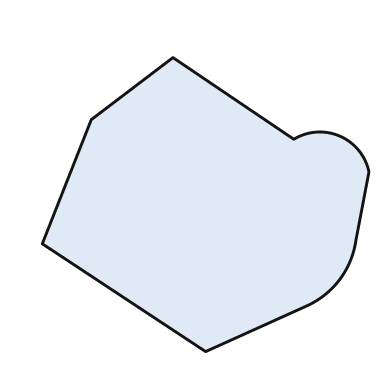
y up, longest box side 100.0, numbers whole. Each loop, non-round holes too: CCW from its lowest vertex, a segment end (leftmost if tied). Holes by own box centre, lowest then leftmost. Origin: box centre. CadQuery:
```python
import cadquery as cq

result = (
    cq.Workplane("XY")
    .moveTo(0.0, -45.0)
    .lineTo(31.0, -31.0)
    .threePointArc((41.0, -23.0), (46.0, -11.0))
    .lineTo(50.0, 10.0)
    .threePointArc((41.0, 21.0), (27.0, 20.0))
    .lineTo(-10.0, 45.0)
    .lineTo(-35.0, 26.0)
    .lineTo(-50.0, -12.0)
    .close()
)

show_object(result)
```